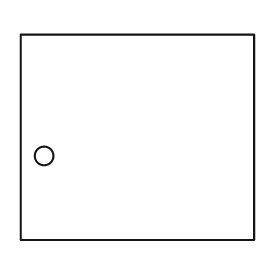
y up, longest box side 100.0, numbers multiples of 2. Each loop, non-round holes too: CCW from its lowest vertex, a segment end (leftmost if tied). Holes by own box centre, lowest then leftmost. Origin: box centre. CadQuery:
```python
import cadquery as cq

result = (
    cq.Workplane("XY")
    .moveTo(-50.0, -44.0)
    .lineTo(50.0, -44.0)
    .lineTo(50.0, 44.0)
    .lineTo(-50.0, 44.0)
    .close()
    .moveTo(-40.0, -8.0)
    .circle(4.0)
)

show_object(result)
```